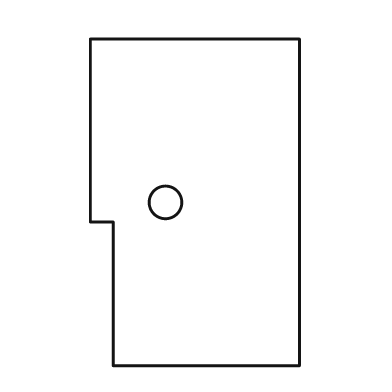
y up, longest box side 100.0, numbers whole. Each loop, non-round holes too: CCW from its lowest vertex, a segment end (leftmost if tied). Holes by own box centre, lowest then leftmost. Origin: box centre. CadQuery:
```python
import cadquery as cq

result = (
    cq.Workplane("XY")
    .moveTo(-25.0, -50.0)
    .lineTo(32.0, -50.0)
    .lineTo(32.0, 50.0)
    .lineTo(-32.0, 50.0)
    .lineTo(-32.0, -6.0)
    .lineTo(-25.0, -6.0)
    .close()
    .moveTo(-9.0, 0.0)
    .circle(5.0)
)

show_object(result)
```